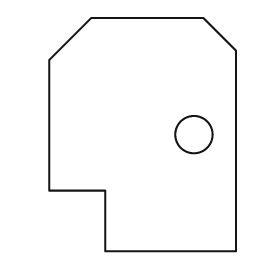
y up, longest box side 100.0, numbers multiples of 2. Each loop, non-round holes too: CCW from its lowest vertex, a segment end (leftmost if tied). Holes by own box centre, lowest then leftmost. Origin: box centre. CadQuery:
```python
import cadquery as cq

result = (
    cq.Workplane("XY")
    .moveTo(-16.0, -50.0)
    .lineTo(40.0, -50.0)
    .lineTo(40.0, 36.0)
    .lineTo(26.0, 50.0)
    .lineTo(-22.0, 50.0)
    .lineTo(-40.0, 32.0)
    .lineTo(-40.0, -24.0)
    .lineTo(-16.0, -24.0)
    .close()
    .moveTo(22.0, 0.0)
    .circle(8.0)
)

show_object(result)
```